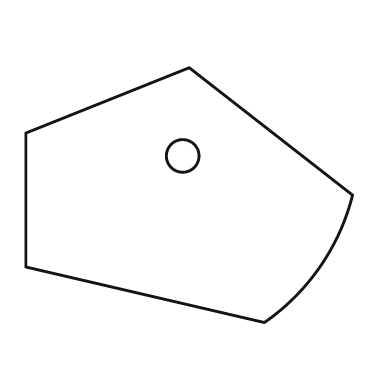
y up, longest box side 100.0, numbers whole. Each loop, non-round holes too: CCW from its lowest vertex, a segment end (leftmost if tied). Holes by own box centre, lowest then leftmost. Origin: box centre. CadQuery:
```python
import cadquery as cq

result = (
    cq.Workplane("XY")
    .moveTo(23.0, -39.0)
    .threePointArc((40.0, -22.0), (50.0, 0.0))
    .lineTo(0.0, 39.0)
    .lineTo(-50.0, 19.0)
    .lineTo(-50.0, -22.0)
    .close()
    .moveTo(-2.0, 12.0)
    .circle(5.0)
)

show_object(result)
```